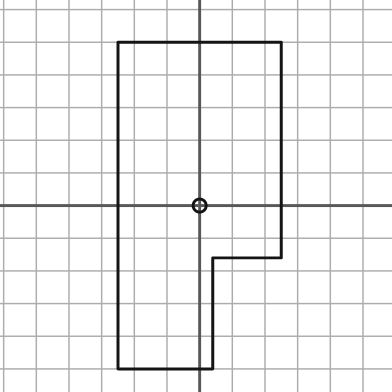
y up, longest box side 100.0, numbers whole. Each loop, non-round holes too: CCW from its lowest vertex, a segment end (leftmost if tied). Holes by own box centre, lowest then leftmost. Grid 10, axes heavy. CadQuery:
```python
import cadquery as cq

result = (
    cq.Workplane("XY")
    .moveTo(-25.0, -50.0)
    .lineTo(4.0, -50.0)
    .lineTo(4.0, -16.0)
    .lineTo(25.0, -16.0)
    .lineTo(25.0, 50.0)
    .lineTo(-25.0, 50.0)
    .close()
    .moveTo(0.0, 0.0)
    .circle(2.0)
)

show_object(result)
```